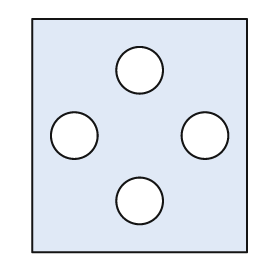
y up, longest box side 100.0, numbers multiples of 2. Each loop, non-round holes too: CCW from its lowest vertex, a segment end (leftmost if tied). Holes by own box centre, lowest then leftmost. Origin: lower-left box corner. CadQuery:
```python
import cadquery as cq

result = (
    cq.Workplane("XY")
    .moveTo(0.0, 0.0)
    .lineTo(92.0, 0.0)
    .lineTo(92.0, 100.0)
    .lineTo(0.0, 100.0)
    .close()
    .moveTo(46.0, 22.0)
    .circle(10.0)
    .moveTo(18.0, 50.0)
    .circle(10.0)
    .moveTo(74.0, 50.0)
    .circle(10.0)
    .moveTo(46.0, 78.0)
    .circle(10.0)
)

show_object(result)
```